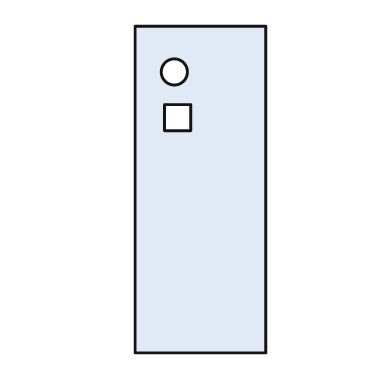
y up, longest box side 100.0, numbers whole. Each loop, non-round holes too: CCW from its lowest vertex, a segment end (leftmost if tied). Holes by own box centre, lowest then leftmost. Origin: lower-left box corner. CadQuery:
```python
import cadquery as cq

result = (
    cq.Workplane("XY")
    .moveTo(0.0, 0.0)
    .lineTo(40.0, 0.0)
    .lineTo(40.0, 100.0)
    .lineTo(0.0, 100.0)
    .close()
    .moveTo(9.0, 68.0)
    .lineTo(17.0, 68.0)
    .lineTo(17.0, 76.0)
    .lineTo(9.0, 76.0)
    .close()
    .moveTo(12.0, 86.0)
    .circle(4.0)
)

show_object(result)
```